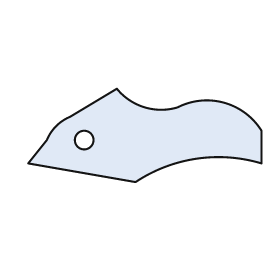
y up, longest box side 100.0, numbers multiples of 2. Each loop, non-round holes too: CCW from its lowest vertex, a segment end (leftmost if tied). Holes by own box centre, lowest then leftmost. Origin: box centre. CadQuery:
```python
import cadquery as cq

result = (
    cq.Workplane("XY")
    .moveTo(-4.0, -20.0)
    .threePointArc((22.0, -10.0), (50.0, -12.0))
    .lineTo(50.0, 2.0)
    .threePointArc((34.0, 14.0), (14.0, 12.0))
    .threePointArc((0.0, 12.0), (-12.0, 20.0))
    .lineTo(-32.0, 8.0)
    .threePointArc((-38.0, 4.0), (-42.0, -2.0))
    .lineTo(-50.0, -12.0)
    .close()
    .moveTo(-26.0, -2.0)
    .circle(4.0)
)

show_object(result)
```